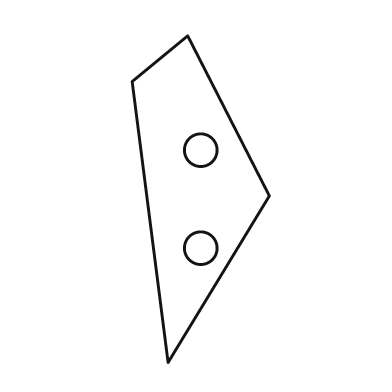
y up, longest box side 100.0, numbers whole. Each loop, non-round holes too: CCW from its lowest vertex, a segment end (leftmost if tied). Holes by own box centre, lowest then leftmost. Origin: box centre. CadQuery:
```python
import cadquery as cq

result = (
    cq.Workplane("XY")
    .moveTo(-10.0, -50.0)
    .lineTo(21.0, 1.0)
    .lineTo(-4.0, 50.0)
    .lineTo(-21.0, 36.0)
    .close()
    .moveTo(0.0, -15.0)
    .circle(5.0)
    .moveTo(0.0, 15.0)
    .circle(5.0)
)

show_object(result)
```